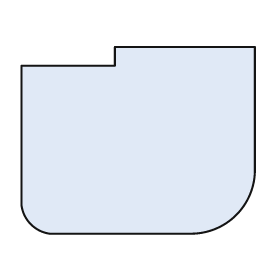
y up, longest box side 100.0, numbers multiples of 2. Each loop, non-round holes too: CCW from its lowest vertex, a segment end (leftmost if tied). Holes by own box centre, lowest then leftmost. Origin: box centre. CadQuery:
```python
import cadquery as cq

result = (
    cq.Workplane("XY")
    .moveTo(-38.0, -40.0)
    .lineTo(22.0, -40.0)
    .threePointArc((42.0, -32.0), (50.0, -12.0))
    .lineTo(50.0, 40.0)
    .lineTo(-10.0, 40.0)
    .lineTo(-10.0, 32.0)
    .lineTo(-50.0, 32.0)
    .lineTo(-50.0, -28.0)
    .threePointArc((-46.0, -36.0), (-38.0, -40.0))
    .close()
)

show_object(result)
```